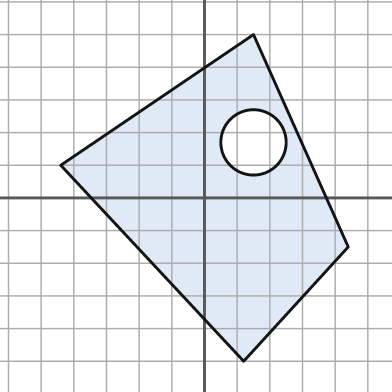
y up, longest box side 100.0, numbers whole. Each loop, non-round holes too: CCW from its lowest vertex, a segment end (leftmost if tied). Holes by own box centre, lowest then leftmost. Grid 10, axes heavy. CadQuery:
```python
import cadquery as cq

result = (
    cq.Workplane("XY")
    .moveTo(12.0, -50.0)
    .lineTo(44.0, -15.0)
    .lineTo(15.0, 50.0)
    .lineTo(-44.0, 10.0)
    .close()
    .moveTo(15.0, 17.0)
    .circle(10.0)
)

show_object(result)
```